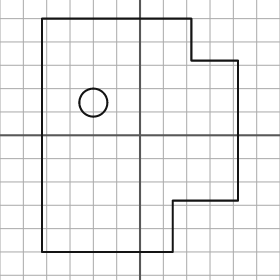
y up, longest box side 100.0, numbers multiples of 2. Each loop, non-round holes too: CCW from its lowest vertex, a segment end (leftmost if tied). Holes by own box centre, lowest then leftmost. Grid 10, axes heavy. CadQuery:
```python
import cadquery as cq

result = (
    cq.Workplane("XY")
    .moveTo(-42.0, -50.0)
    .lineTo(14.0, -50.0)
    .lineTo(14.0, -28.0)
    .lineTo(42.0, -28.0)
    .lineTo(42.0, 32.0)
    .lineTo(22.0, 32.0)
    .lineTo(22.0, 50.0)
    .lineTo(-42.0, 50.0)
    .close()
    .moveTo(-20.0, 14.0)
    .circle(6.0)
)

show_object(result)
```